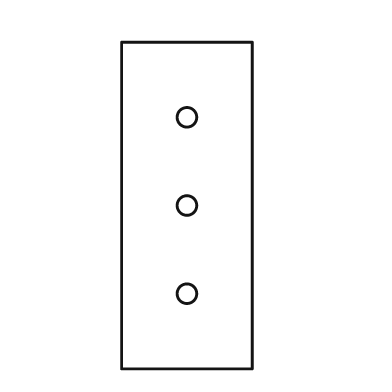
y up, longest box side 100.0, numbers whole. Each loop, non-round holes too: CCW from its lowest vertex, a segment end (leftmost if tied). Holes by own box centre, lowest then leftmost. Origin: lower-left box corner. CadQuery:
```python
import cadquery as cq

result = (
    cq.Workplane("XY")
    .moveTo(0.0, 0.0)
    .lineTo(40.0, 0.0)
    .lineTo(40.0, 100.0)
    .lineTo(0.0, 100.0)
    .close()
    .moveTo(20.0, 23.0)
    .circle(3.0)
    .moveTo(20.0, 50.0)
    .circle(3.0)
    .moveTo(20.0, 77.0)
    .circle(3.0)
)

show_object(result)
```